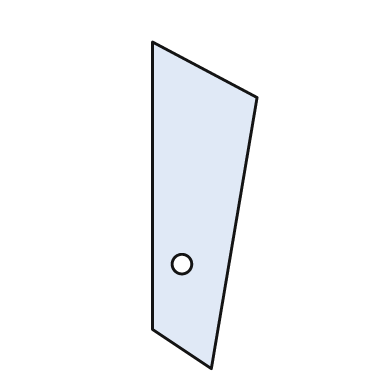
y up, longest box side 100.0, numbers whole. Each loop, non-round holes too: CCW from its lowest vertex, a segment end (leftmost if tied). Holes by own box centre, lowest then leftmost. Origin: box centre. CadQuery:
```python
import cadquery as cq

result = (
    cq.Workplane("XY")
    .moveTo(2.0, -50.0)
    .lineTo(16.0, 33.0)
    .lineTo(-16.0, 50.0)
    .lineTo(-16.0, -38.0)
    .close()
    .moveTo(-7.0, -18.0)
    .circle(3.0)
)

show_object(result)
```